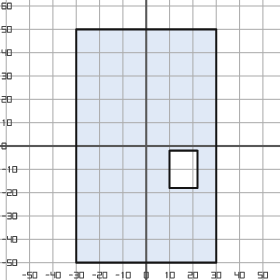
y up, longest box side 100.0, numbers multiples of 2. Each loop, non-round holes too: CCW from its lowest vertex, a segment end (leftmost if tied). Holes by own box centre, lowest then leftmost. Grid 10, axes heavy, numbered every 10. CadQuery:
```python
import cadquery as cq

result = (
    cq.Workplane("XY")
    .moveTo(-30.0, -50.0)
    .lineTo(30.0, -50.0)
    .lineTo(30.0, 50.0)
    .lineTo(-30.0, 50.0)
    .close()
    .moveTo(10.0, -18.0)
    .lineTo(22.0, -18.0)
    .lineTo(22.0, -2.0)
    .lineTo(10.0, -2.0)
    .close()
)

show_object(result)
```